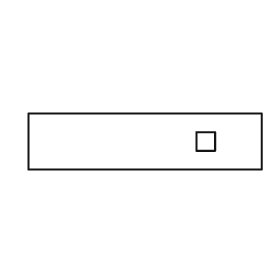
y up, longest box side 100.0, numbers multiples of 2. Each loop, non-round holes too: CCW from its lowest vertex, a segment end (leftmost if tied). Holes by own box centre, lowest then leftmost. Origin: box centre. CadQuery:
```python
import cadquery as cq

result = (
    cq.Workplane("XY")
    .moveTo(-50.0, -12.0)
    .lineTo(50.0, -12.0)
    .lineTo(50.0, 12.0)
    .lineTo(-50.0, 12.0)
    .close()
    .moveTo(22.0, -4.0)
    .lineTo(30.0, -4.0)
    .lineTo(30.0, 4.0)
    .lineTo(22.0, 4.0)
    .close()
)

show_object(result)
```